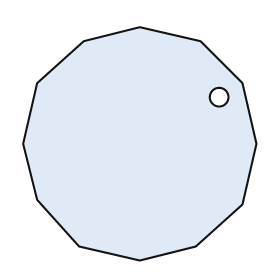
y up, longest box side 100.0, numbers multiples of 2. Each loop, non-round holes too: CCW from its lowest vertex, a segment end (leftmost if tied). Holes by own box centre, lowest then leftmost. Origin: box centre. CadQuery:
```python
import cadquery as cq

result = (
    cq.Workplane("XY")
    .moveTo(0.0, -50.0)
    .lineTo(24.0, -44.0)
    .lineTo(44.0, -26.0)
    .lineTo(50.0, 0.0)
    .lineTo(44.0, 26.0)
    .lineTo(26.0, 44.0)
    .lineTo(0.0, 50.0)
    .lineTo(-24.0, 44.0)
    .lineTo(-44.0, 26.0)
    .lineTo(-50.0, 0.0)
    .lineTo(-44.0, -24.0)
    .lineTo(-26.0, -44.0)
    .close()
    .moveTo(34.0, 20.0)
    .circle(4.0)
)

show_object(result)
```